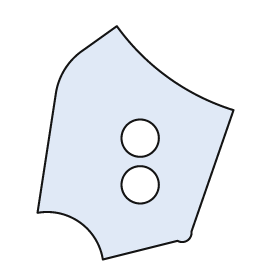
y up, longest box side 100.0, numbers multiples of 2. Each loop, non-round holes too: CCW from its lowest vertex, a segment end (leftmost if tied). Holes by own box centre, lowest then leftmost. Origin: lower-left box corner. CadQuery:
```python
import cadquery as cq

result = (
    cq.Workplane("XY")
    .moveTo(28.0, 0.0)
    .lineTo(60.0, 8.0)
    .threePointArc((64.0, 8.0), (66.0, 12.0))
    .lineTo(84.0, 64.0)
    .threePointArc((56.0, 78.0), (34.0, 100.0))
    .lineTo(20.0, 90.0)
    .threePointArc((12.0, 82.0), (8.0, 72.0))
    .lineTo(0.0, 20.0)
    .threePointArc((18.0, 16.0), (28.0, 0.0))
    .close()
    .moveTo(44.0, 32.0)
    .circle(8.0)
    .moveTo(44.0, 52.0)
    .circle(8.0)
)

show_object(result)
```